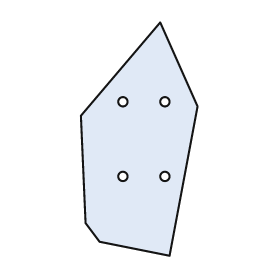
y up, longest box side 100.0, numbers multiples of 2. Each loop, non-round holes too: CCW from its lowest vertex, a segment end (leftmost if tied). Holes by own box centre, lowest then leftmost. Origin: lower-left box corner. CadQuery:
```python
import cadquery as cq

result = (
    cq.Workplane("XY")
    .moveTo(38.0, 0.0)
    .lineTo(50.0, 64.0)
    .lineTo(34.0, 100.0)
    .lineTo(0.0, 60.0)
    .lineTo(2.0, 14.0)
    .lineTo(8.0, 6.0)
    .close()
    .moveTo(18.0, 34.0)
    .circle(2.0)
    .moveTo(36.0, 34.0)
    .circle(2.0)
    .moveTo(18.0, 66.0)
    .circle(2.0)
    .moveTo(36.0, 66.0)
    .circle(2.0)
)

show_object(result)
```